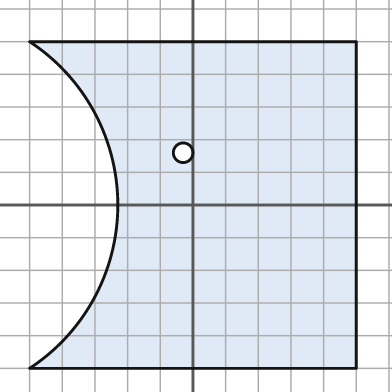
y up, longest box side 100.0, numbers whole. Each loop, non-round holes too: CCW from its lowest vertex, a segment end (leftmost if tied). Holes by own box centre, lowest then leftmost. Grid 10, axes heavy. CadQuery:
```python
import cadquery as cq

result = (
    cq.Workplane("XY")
    .moveTo(-50.0, -50.0)
    .lineTo(50.0, -50.0)
    .lineTo(50.0, 50.0)
    .lineTo(-50.0, 50.0)
    .threePointArc((-23.0, 0.0), (-50.0, -50.0))
    .close()
    .moveTo(-3.0, 16.0)
    .circle(3.0)
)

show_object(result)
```